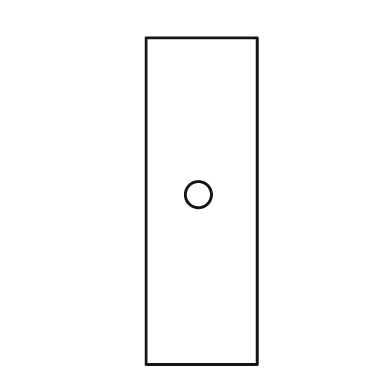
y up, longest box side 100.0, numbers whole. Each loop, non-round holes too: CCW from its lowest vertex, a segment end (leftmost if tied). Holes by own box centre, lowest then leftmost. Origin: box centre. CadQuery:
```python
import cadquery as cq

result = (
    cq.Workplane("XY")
    .moveTo(-17.0, -50.0)
    .lineTo(17.0, -50.0)
    .lineTo(17.0, 50.0)
    .lineTo(-17.0, 50.0)
    .close()
    .moveTo(-1.0, 2.0)
    .circle(4.0)
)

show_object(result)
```